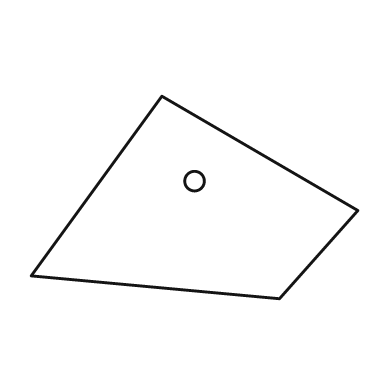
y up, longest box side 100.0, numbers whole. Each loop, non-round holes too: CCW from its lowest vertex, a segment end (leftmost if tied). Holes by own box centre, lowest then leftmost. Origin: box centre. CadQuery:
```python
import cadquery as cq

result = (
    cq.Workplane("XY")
    .moveTo(26.0, -31.0)
    .lineTo(50.0, -4.0)
    .lineTo(-10.0, 31.0)
    .lineTo(-50.0, -24.0)
    .close()
    .moveTo(0.0, 5.0)
    .circle(3.0)
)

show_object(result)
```